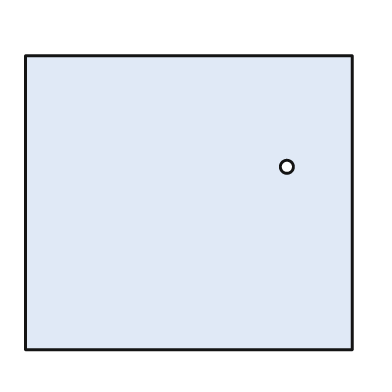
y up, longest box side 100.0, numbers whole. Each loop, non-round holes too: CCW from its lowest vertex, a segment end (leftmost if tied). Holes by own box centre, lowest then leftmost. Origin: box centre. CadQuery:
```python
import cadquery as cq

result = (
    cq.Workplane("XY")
    .moveTo(-50.0, -45.0)
    .lineTo(50.0, -45.0)
    .lineTo(50.0, 45.0)
    .lineTo(-50.0, 45.0)
    .close()
    .moveTo(30.0, 11.0)
    .circle(2.0)
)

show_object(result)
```